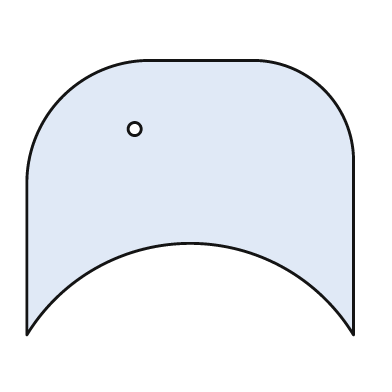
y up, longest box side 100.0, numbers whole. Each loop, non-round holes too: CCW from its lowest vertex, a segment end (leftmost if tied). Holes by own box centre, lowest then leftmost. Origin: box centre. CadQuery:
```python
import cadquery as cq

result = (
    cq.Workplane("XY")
    .moveTo(-50.0, -42.0)
    .threePointArc((0.0, -14.0), (50.0, -42.0))
    .lineTo(50.0, 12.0)
    .threePointArc((41.0, 33.0), (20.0, 42.0))
    .lineTo(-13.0, 42.0)
    .threePointArc((-39.0, 31.0), (-50.0, 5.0))
    .close()
    .moveTo(-17.0, 21.0)
    .circle(2.0)
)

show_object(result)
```